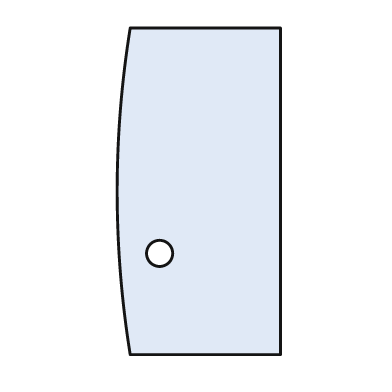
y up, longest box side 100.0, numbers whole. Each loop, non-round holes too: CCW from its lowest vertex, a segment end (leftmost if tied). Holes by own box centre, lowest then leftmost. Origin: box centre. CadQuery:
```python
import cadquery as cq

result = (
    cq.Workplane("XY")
    .moveTo(-21.0, -50.0)
    .lineTo(25.0, -50.0)
    .lineTo(25.0, 50.0)
    .lineTo(-21.0, 50.0)
    .threePointArc((-25.0, 0.0), (-21.0, -50.0))
    .close()
    .moveTo(-12.0, -19.0)
    .circle(4.0)
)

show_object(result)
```